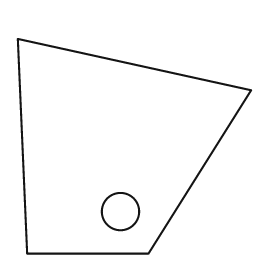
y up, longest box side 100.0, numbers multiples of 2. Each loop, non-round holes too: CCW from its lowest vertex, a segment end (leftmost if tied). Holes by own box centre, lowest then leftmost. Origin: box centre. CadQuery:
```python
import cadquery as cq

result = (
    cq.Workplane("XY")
    .moveTo(-46.0, -46.0)
    .lineTo(6.0, -46.0)
    .lineTo(50.0, 24.0)
    .lineTo(-50.0, 46.0)
    .close()
    .moveTo(-6.0, -28.0)
    .circle(8.0)
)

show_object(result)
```